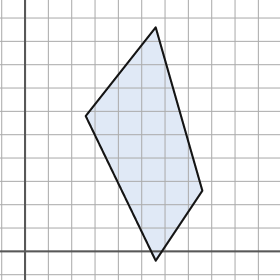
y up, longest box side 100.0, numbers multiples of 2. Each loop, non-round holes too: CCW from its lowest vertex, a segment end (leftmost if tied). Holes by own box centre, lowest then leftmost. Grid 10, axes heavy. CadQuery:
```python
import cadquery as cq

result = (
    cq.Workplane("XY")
    .moveTo(56.0, -4.0)
    .lineTo(76.0, 26.0)
    .lineTo(56.0, 96.0)
    .lineTo(26.0, 58.0)
    .close()
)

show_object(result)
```